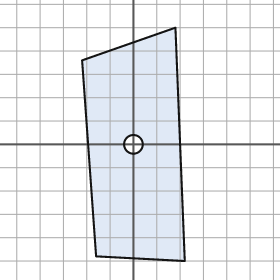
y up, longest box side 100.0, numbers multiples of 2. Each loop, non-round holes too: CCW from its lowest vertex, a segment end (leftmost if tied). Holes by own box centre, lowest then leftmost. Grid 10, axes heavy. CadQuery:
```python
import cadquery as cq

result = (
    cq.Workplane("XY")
    .moveTo(22.0, -50.0)
    .lineTo(18.0, 50.0)
    .lineTo(-22.0, 36.0)
    .lineTo(-16.0, -48.0)
    .close()
    .moveTo(0.0, 0.0)
    .circle(4.0)
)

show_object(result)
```